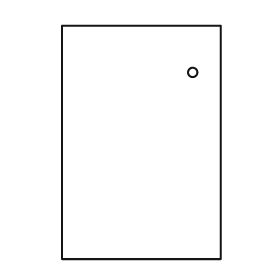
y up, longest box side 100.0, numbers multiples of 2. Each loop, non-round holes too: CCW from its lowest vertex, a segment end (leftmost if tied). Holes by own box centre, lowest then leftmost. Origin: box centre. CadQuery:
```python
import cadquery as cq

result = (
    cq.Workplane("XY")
    .moveTo(-34.0, -50.0)
    .lineTo(34.0, -50.0)
    .lineTo(34.0, 50.0)
    .lineTo(-34.0, 50.0)
    .close()
    .moveTo(22.0, 30.0)
    .circle(2.0)
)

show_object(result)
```